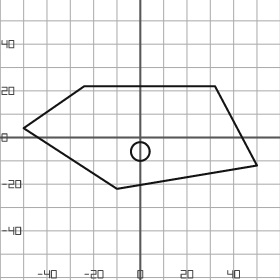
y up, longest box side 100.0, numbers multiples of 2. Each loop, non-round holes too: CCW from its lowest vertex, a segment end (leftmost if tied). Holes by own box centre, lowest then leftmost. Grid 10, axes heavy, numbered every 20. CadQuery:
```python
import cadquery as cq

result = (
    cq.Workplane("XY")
    .moveTo(-10.0, -22.0)
    .lineTo(50.0, -12.0)
    .lineTo(32.0, 22.0)
    .lineTo(-24.0, 22.0)
    .lineTo(-50.0, 4.0)
    .close()
    .moveTo(0.0, -6.0)
    .circle(4.0)
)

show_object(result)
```